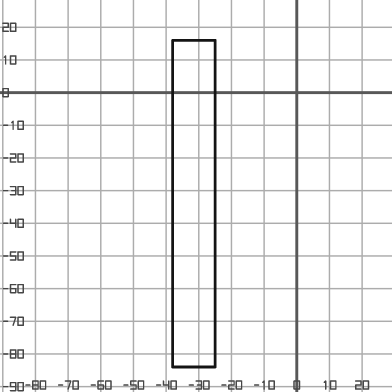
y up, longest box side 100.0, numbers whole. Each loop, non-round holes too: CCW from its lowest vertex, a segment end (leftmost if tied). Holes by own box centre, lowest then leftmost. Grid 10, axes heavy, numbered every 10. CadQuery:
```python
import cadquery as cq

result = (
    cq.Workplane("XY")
    .moveTo(-38.0, -84.0)
    .lineTo(-25.0, -84.0)
    .lineTo(-25.0, 16.0)
    .lineTo(-38.0, 16.0)
    .close()
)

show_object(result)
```